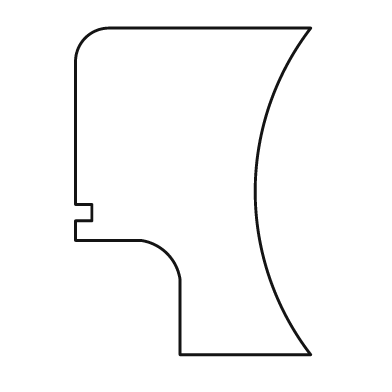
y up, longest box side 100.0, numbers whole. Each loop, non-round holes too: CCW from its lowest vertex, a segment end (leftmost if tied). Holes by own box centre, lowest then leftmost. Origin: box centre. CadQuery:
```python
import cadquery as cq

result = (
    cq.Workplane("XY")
    .moveTo(-4.0, -50.0)
    .lineTo(36.0, -50.0)
    .threePointArc((19.0, 0.0), (36.0, 50.0))
    .lineTo(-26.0, 50.0)
    .threePointArc((-33.0, 47.0), (-36.0, 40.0))
    .lineTo(-36.0, -4.0)
    .lineTo(-31.0, -4.0)
    .lineTo(-31.0, -9.0)
    .lineTo(-36.0, -9.0)
    .lineTo(-36.0, -15.0)
    .lineTo(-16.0, -15.0)
    .threePointArc((-8.0, -19.0), (-4.0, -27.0))
    .close()
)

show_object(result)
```